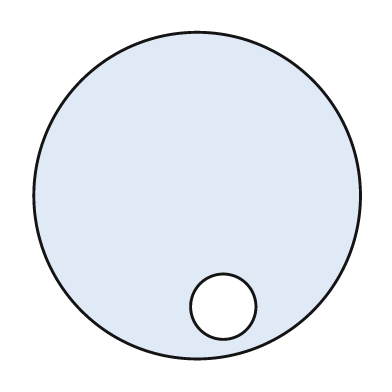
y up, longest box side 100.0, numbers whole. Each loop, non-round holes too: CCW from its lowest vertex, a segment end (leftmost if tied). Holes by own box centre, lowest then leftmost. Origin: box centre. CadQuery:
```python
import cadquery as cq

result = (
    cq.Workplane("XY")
    .moveTo(0.0, 0.0)
    .circle(50.0)
    .moveTo(8.0, -34.0)
    .circle(10.0)
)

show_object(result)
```